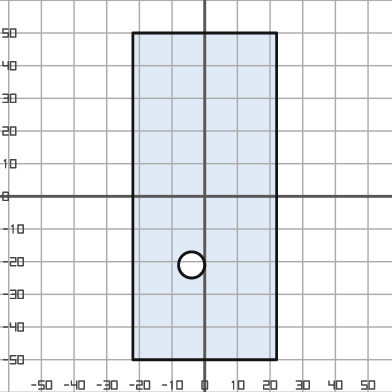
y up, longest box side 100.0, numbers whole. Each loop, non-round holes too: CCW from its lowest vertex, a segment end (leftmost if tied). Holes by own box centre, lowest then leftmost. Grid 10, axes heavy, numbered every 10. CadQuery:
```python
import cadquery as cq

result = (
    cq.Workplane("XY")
    .moveTo(-22.0, -50.0)
    .lineTo(22.0, -50.0)
    .lineTo(22.0, 50.0)
    .lineTo(-22.0, 50.0)
    .close()
    .moveTo(-4.0, -21.0)
    .circle(4.0)
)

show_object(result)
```